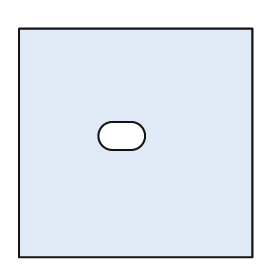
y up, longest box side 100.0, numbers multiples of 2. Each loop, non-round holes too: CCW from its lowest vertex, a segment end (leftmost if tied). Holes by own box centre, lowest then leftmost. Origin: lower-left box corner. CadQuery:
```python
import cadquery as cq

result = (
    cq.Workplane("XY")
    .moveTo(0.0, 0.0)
    .lineTo(100.0, 0.0)
    .lineTo(100.0, 98.0)
    .lineTo(0.0, 98.0)
    .close()
    .moveTo(40.0, 46.0)
    .lineTo(48.0, 46.0)
    .threePointArc((54.0, 52.0), (48.0, 58.0))
    .lineTo(40.0, 58.0)
    .threePointArc((34.0, 52.0), (40.0, 46.0))
    .close()
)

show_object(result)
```